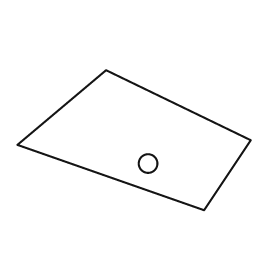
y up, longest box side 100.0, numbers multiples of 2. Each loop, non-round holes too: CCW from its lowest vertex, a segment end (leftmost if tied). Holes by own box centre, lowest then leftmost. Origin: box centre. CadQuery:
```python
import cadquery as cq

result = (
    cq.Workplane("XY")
    .moveTo(30.0, -30.0)
    .lineTo(50.0, 0.0)
    .lineTo(-12.0, 30.0)
    .lineTo(-50.0, -2.0)
    .close()
    .moveTo(6.0, -10.0)
    .circle(4.0)
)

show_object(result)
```